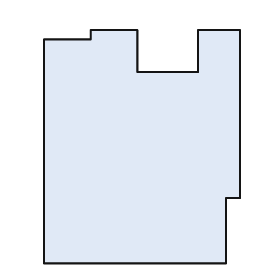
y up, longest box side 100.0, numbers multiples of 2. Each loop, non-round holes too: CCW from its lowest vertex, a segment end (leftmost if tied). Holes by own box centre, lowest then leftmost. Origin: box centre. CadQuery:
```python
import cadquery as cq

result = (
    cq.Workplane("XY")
    .moveTo(-42.0, -50.0)
    .lineTo(36.0, -50.0)
    .lineTo(36.0, -22.0)
    .lineTo(42.0, -22.0)
    .lineTo(42.0, 50.0)
    .lineTo(24.0, 50.0)
    .lineTo(24.0, 32.0)
    .lineTo(-2.0, 32.0)
    .lineTo(-2.0, 50.0)
    .lineTo(-22.0, 50.0)
    .lineTo(-22.0, 46.0)
    .lineTo(-42.0, 46.0)
    .close()
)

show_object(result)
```